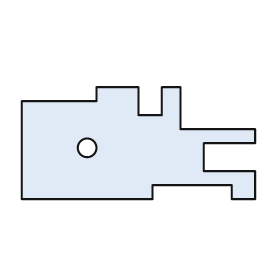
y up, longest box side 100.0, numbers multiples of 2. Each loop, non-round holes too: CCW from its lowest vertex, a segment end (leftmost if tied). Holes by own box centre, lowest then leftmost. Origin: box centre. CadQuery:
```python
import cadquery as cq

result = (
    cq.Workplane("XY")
    .moveTo(-50.0, -24.0)
    .lineTo(6.0, -24.0)
    .lineTo(6.0, -18.0)
    .lineTo(40.0, -18.0)
    .lineTo(40.0, -24.0)
    .lineTo(50.0, -24.0)
    .lineTo(50.0, -12.0)
    .lineTo(28.0, -12.0)
    .lineTo(28.0, 0.0)
    .lineTo(50.0, 0.0)
    .lineTo(50.0, 6.0)
    .lineTo(18.0, 6.0)
    .lineTo(18.0, 24.0)
    .lineTo(10.0, 24.0)
    .lineTo(10.0, 12.0)
    .lineTo(0.0, 12.0)
    .lineTo(0.0, 24.0)
    .lineTo(-18.0, 24.0)
    .lineTo(-18.0, 18.0)
    .lineTo(-50.0, 18.0)
    .close()
    .moveTo(-22.0, -2.0)
    .circle(4.0)
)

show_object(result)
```